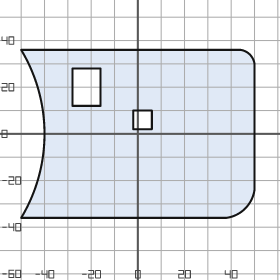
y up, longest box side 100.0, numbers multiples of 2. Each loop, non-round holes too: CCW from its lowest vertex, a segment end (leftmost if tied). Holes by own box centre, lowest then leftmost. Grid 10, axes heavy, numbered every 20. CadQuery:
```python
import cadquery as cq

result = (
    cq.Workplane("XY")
    .moveTo(-50.0, -36.0)
    .lineTo(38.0, -36.0)
    .threePointArc((46.0, -32.0), (50.0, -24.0))
    .lineTo(50.0, 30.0)
    .threePointArc((48.0, 34.0), (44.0, 36.0))
    .lineTo(-50.0, 36.0)
    .threePointArc((-40.0, 0.0), (-50.0, -36.0))
    .close()
    .moveTo(-2.0, 2.0)
    .lineTo(6.0, 2.0)
    .lineTo(6.0, 10.0)
    .lineTo(-2.0, 10.0)
    .close()
    .moveTo(-28.0, 12.0)
    .lineTo(-16.0, 12.0)
    .lineTo(-16.0, 28.0)
    .lineTo(-28.0, 28.0)
    .close()
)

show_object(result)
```